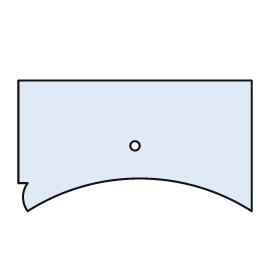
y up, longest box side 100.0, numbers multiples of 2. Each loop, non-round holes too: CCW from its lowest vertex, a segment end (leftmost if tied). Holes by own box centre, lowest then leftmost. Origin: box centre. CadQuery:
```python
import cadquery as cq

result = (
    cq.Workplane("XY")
    .moveTo(-46.0, -28.0)
    .threePointArc((2.0, -14.0), (50.0, -28.0))
    .lineTo(50.0, 28.0)
    .lineTo(-50.0, 28.0)
    .lineTo(-50.0, -16.0)
    .lineTo(-46.0, -16.0)
    .threePointArc((-48.0, -22.0), (-46.0, -28.0))
    .close()
    .moveTo(0.0, 0.0)
    .circle(2.0)
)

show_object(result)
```